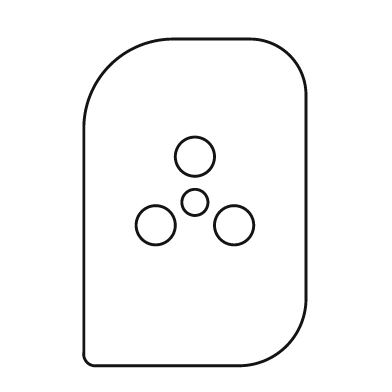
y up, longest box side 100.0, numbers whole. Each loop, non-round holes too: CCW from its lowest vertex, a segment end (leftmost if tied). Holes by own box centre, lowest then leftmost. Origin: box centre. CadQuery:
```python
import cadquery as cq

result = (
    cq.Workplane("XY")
    .moveTo(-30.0, -50.0)
    .lineTo(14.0, -50.0)
    .threePointArc((28.0, -44.0), (34.0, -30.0))
    .lineTo(34.0, 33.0)
    .threePointArc((29.0, 45.0), (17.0, 50.0))
    .lineTo(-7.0, 50.0)
    .threePointArc((-26.0, 42.0), (-34.0, 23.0))
    .lineTo(-34.0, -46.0)
    .threePointArc((-33.0, -49.0), (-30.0, -50.0))
    .close()
    .moveTo(-12.0, -7.0)
    .circle(6.0)
    .moveTo(12.0, -7.0)
    .circle(6.0)
    .moveTo(0.0, 0.0)
    .circle(4.0)
    .moveTo(0.0, 14.0)
    .circle(6.0)
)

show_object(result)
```